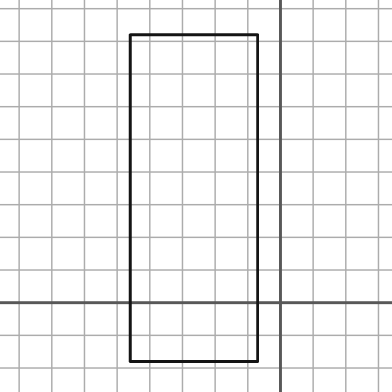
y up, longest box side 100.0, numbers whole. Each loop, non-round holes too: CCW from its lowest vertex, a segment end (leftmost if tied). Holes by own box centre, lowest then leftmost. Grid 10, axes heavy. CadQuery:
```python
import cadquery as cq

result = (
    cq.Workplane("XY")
    .moveTo(-46.0, -18.0)
    .lineTo(-7.0, -18.0)
    .lineTo(-7.0, 82.0)
    .lineTo(-46.0, 82.0)
    .close()
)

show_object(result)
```